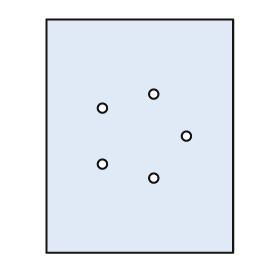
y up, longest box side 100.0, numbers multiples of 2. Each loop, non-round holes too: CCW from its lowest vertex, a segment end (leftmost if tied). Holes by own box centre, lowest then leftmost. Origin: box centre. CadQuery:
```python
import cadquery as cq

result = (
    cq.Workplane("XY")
    .moveTo(-40.0, -50.0)
    .lineTo(40.0, -50.0)
    .lineTo(40.0, 50.0)
    .lineTo(-40.0, 50.0)
    .close()
    .moveTo(6.0, -18.0)
    .circle(2.0)
    .moveTo(-16.0, -12.0)
    .circle(2.0)
    .moveTo(20.0, 0.0)
    .circle(2.0)
    .moveTo(-16.0, 12.0)
    .circle(2.0)
    .moveTo(6.0, 18.0)
    .circle(2.0)
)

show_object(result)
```